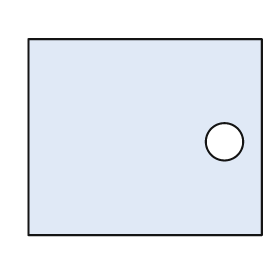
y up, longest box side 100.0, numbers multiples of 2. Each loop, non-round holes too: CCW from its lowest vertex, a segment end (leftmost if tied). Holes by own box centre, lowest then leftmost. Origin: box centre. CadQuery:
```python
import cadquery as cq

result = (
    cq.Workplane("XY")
    .moveTo(-50.0, -42.0)
    .lineTo(50.0, -42.0)
    .lineTo(50.0, 42.0)
    .lineTo(-50.0, 42.0)
    .close()
    .moveTo(34.0, -2.0)
    .circle(8.0)
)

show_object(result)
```